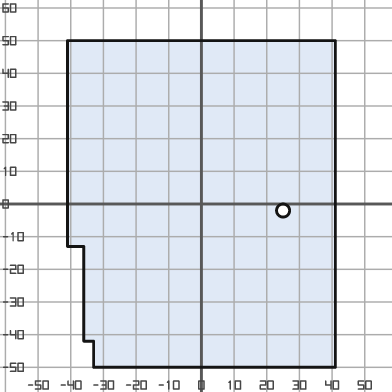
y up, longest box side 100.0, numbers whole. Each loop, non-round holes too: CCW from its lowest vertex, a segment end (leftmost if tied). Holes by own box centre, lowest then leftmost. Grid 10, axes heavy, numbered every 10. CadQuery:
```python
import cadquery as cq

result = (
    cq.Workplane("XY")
    .moveTo(-33.0, -50.0)
    .lineTo(41.0, -50.0)
    .lineTo(41.0, 50.0)
    .lineTo(-41.0, 50.0)
    .lineTo(-41.0, -13.0)
    .lineTo(-36.0, -13.0)
    .lineTo(-36.0, -42.0)
    .lineTo(-33.0, -42.0)
    .close()
    .moveTo(25.0, -2.0)
    .circle(2.0)
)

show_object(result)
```